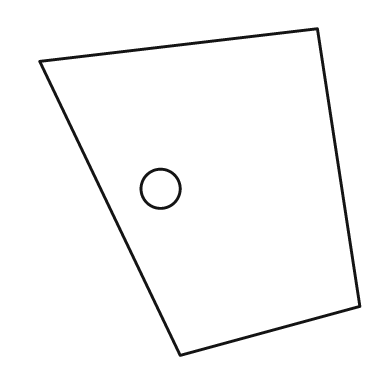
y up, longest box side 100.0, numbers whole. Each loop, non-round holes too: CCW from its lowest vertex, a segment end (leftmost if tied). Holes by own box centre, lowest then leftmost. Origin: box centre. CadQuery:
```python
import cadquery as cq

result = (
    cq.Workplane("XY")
    .moveTo(-6.0, -50.0)
    .lineTo(49.0, -35.0)
    .lineTo(36.0, 50.0)
    .lineTo(-49.0, 40.0)
    .close()
    .moveTo(-12.0, 1.0)
    .circle(6.0)
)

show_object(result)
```